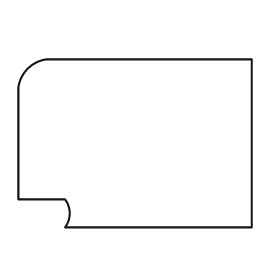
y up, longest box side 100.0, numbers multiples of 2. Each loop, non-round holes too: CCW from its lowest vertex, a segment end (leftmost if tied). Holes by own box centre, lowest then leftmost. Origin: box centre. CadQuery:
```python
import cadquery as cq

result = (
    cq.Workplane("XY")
    .moveTo(-30.0, -36.0)
    .lineTo(50.0, -36.0)
    .lineTo(50.0, 36.0)
    .lineTo(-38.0, 36.0)
    .threePointArc((-46.0, 32.0), (-50.0, 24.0))
    .lineTo(-50.0, -24.0)
    .lineTo(-30.0, -24.0)
    .threePointArc((-28.0, -30.0), (-30.0, -36.0))
    .close()
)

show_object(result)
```